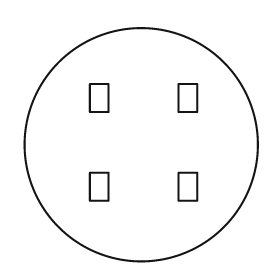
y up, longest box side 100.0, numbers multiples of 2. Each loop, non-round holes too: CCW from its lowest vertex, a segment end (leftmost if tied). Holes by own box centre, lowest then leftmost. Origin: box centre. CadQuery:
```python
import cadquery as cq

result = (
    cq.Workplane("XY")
    .moveTo(0.0, 0.0)
    .circle(50.0)
    .moveTo(-22.0, -24.0)
    .lineTo(-14.0, -24.0)
    .lineTo(-14.0, -12.0)
    .lineTo(-22.0, -12.0)
    .close()
    .moveTo(16.0, -24.0)
    .lineTo(24.0, -24.0)
    .lineTo(24.0, -12.0)
    .lineTo(16.0, -12.0)
    .close()
    .moveTo(-22.0, 14.0)
    .lineTo(-14.0, 14.0)
    .lineTo(-14.0, 26.0)
    .lineTo(-22.0, 26.0)
    .close()
    .moveTo(16.0, 14.0)
    .lineTo(24.0, 14.0)
    .lineTo(24.0, 26.0)
    .lineTo(16.0, 26.0)
    .close()
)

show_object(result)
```